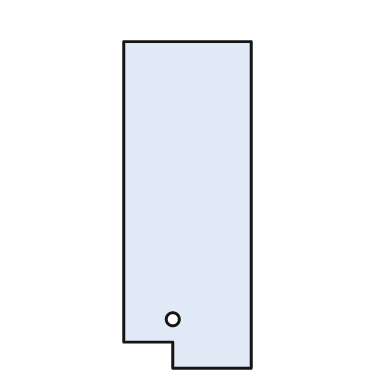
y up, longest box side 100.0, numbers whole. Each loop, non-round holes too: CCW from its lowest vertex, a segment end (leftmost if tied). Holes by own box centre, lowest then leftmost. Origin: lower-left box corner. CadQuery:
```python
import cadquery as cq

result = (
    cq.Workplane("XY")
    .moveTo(15.0, 0.0)
    .lineTo(39.0, 0.0)
    .lineTo(39.0, 100.0)
    .lineTo(0.0, 100.0)
    .lineTo(0.0, 8.0)
    .lineTo(15.0, 8.0)
    .close()
    .moveTo(15.0, 15.0)
    .circle(2.0)
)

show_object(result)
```